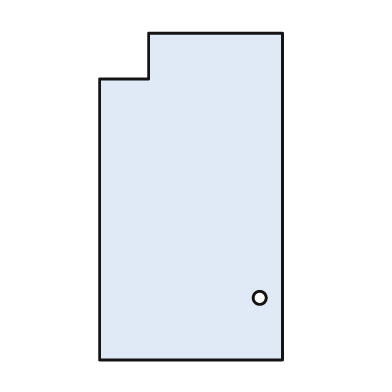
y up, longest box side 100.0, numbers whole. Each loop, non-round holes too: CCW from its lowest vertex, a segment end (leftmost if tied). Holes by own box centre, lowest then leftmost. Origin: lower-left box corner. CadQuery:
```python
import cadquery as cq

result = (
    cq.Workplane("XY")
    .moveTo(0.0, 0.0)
    .lineTo(56.0, 0.0)
    .lineTo(56.0, 100.0)
    .lineTo(15.0, 100.0)
    .lineTo(15.0, 86.0)
    .lineTo(0.0, 86.0)
    .close()
    .moveTo(49.0, 19.0)
    .circle(2.0)
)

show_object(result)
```